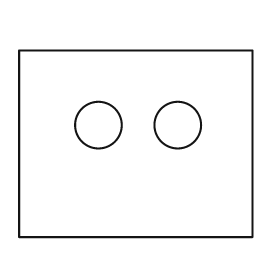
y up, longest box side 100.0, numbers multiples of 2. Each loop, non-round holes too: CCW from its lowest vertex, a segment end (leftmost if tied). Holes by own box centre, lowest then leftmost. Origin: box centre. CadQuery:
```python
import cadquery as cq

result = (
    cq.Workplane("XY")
    .moveTo(-50.0, -40.0)
    .lineTo(50.0, -40.0)
    .lineTo(50.0, 40.0)
    .lineTo(-50.0, 40.0)
    .close()
    .moveTo(-16.0, 8.0)
    .circle(10.0)
    .moveTo(18.0, 8.0)
    .circle(10.0)
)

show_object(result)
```